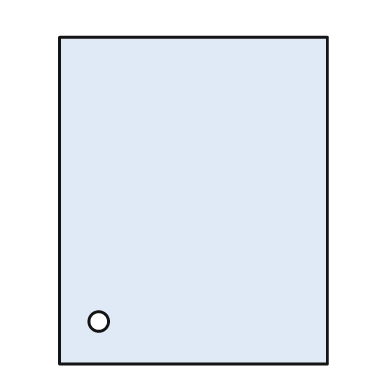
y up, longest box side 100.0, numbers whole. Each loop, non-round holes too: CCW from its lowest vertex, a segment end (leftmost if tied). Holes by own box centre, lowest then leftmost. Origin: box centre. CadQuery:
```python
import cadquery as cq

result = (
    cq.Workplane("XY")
    .moveTo(-41.0, -50.0)
    .lineTo(41.0, -50.0)
    .lineTo(41.0, 50.0)
    .lineTo(-41.0, 50.0)
    .close()
    .moveTo(-29.0, -37.0)
    .circle(3.0)
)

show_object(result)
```